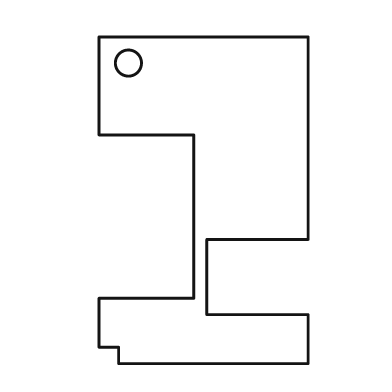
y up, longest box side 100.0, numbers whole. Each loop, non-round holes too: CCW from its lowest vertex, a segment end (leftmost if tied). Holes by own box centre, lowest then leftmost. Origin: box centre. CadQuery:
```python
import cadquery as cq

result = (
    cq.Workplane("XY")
    .moveTo(-26.0, -50.0)
    .lineTo(32.0, -50.0)
    .lineTo(32.0, -35.0)
    .lineTo(1.0, -35.0)
    .lineTo(1.0, -12.0)
    .lineTo(32.0, -12.0)
    .lineTo(32.0, 50.0)
    .lineTo(-32.0, 50.0)
    .lineTo(-32.0, 20.0)
    .lineTo(-3.0, 20.0)
    .lineTo(-3.0, -30.0)
    .lineTo(-32.0, -30.0)
    .lineTo(-32.0, -45.0)
    .lineTo(-26.0, -45.0)
    .close()
    .moveTo(-23.0, 42.0)
    .circle(4.0)
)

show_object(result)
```